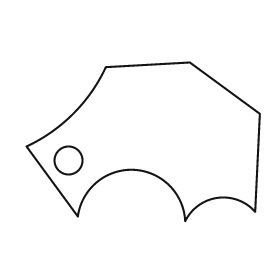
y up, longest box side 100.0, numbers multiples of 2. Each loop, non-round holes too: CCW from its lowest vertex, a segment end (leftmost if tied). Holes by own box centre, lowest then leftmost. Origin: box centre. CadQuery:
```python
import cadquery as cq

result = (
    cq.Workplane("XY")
    .moveTo(18.0, -34.0)
    .threePointArc((32.0, -24.0), (48.0, -30.0))
    .lineTo(50.0, 12.0)
    .lineTo(20.0, 34.0)
    .lineTo(-16.0, 32.0)
    .threePointArc((-30.0, 12.0), (-50.0, -2.0))
    .lineTo(-28.0, -32.0)
    .threePointArc((-4.0, -12.0), (18.0, -34.0))
    .close()
    .moveTo(-32.0, -8.0)
    .circle(6.0)
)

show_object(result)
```